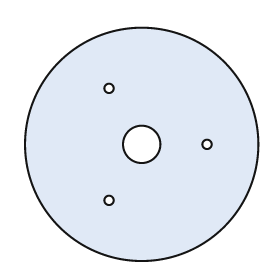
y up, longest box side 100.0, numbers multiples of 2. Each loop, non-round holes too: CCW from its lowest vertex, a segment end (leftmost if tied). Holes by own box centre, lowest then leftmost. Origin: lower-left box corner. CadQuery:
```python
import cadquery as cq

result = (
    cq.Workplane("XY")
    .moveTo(50.0, 50.0)
    .circle(50.0)
    .moveTo(36.0, 26.0)
    .circle(2.0)
    .moveTo(50.0, 50.0)
    .circle(8.0)
    .moveTo(78.0, 50.0)
    .circle(2.0)
    .moveTo(36.0, 74.0)
    .circle(2.0)
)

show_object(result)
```